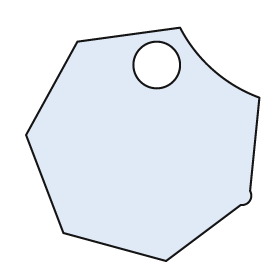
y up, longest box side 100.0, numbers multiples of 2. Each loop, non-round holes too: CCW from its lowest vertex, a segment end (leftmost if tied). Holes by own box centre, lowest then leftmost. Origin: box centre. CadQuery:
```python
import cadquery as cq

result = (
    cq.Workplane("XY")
    .moveTo(10.0, -50.0)
    .lineTo(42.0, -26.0)
    .threePointArc((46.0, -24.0), (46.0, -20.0))
    .lineTo(50.0, 20.0)
    .threePointArc((30.0, 32.0), (16.0, 50.0))
    .lineTo(-28.0, 44.0)
    .lineTo(-50.0, 4.0)
    .lineTo(-34.0, -38.0)
    .close()
    .moveTo(6.0, 34.0)
    .circle(10.0)
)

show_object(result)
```